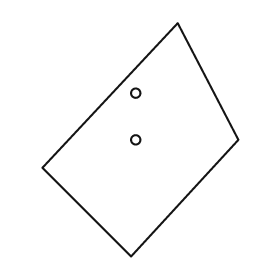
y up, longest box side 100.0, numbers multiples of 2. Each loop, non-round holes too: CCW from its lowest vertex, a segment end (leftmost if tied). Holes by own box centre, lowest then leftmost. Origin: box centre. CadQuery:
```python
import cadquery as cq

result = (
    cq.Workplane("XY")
    .moveTo(-4.0, -50.0)
    .lineTo(42.0, 0.0)
    .lineTo(16.0, 50.0)
    .lineTo(-42.0, -12.0)
    .close()
    .moveTo(-2.0, 0.0)
    .circle(2.0)
    .moveTo(-2.0, 20.0)
    .circle(2.0)
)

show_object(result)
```